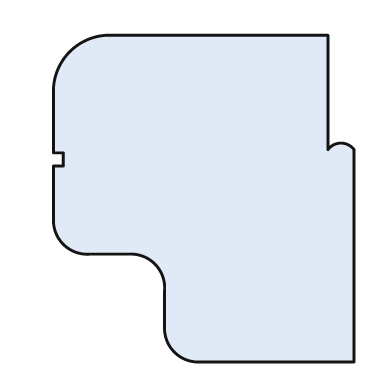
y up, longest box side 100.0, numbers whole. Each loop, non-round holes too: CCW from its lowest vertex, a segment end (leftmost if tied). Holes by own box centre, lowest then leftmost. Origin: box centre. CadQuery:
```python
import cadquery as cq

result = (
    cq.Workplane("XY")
    .moveTo(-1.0, -50.0)
    .lineTo(46.0, -50.0)
    .lineTo(46.0, 15.0)
    .threePointArc((42.0, 17.0), (38.0, 15.0))
    .lineTo(38.0, 50.0)
    .lineTo(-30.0, 50.0)
    .threePointArc((-41.0, 45.0), (-46.0, 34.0))
    .lineTo(-46.0, 14.0)
    .lineTo(-43.0, 14.0)
    .lineTo(-43.0, 10.0)
    .lineTo(-46.0, 10.0)
    .lineTo(-46.0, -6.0)
    .threePointArc((-43.0, -14.0), (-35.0, -17.0))
    .lineTo(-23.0, -17.0)
    .threePointArc((-15.0, -20.0), (-12.0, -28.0))
    .lineTo(-12.0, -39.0)
    .threePointArc((-9.0, -47.0), (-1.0, -50.0))
    .close()
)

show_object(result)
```